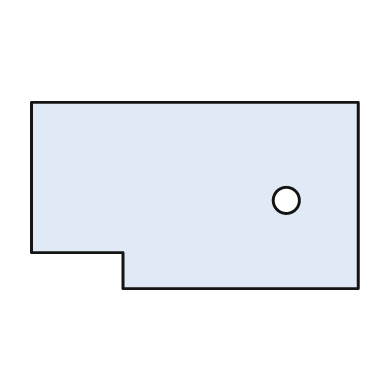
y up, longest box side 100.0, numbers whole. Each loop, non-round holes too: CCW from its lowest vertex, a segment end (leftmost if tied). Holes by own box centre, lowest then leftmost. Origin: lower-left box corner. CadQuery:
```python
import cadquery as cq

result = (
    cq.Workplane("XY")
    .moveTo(28.0, 0.0)
    .lineTo(100.0, 0.0)
    .lineTo(100.0, 57.0)
    .lineTo(0.0, 57.0)
    .lineTo(0.0, 11.0)
    .lineTo(28.0, 11.0)
    .close()
    .moveTo(78.0, 27.0)
    .circle(4.0)
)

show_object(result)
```